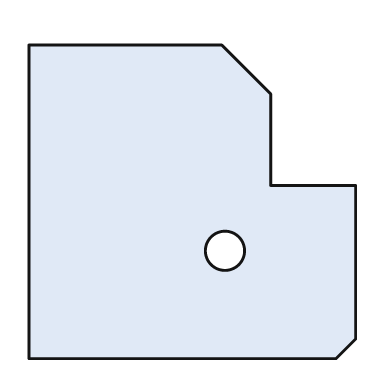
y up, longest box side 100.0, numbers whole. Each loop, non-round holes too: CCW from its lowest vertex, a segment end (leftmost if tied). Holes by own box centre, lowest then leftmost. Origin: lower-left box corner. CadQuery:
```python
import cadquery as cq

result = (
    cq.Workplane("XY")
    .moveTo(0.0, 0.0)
    .lineTo(94.0, 0.0)
    .lineTo(100.0, 6.0)
    .lineTo(100.0, 53.0)
    .lineTo(74.0, 53.0)
    .lineTo(74.0, 81.0)
    .lineTo(59.0, 96.0)
    .lineTo(0.0, 96.0)
    .close()
    .moveTo(60.0, 33.0)
    .circle(6.0)
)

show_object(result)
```